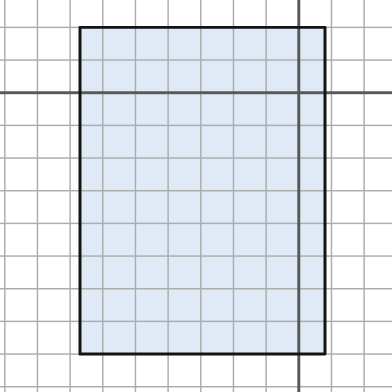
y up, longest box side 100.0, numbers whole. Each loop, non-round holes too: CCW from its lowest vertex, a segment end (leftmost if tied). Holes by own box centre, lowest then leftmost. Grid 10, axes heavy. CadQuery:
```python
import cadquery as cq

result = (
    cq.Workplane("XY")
    .moveTo(-67.0, -80.0)
    .lineTo(8.0, -80.0)
    .lineTo(8.0, 20.0)
    .lineTo(-67.0, 20.0)
    .close()
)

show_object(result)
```